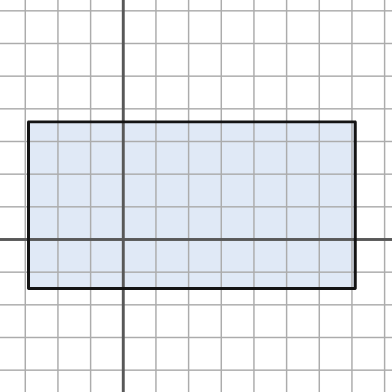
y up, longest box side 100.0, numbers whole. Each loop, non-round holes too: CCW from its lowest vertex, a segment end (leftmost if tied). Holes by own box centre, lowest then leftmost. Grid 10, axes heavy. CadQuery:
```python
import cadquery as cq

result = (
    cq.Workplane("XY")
    .moveTo(-29.0, -15.0)
    .lineTo(71.0, -15.0)
    .lineTo(71.0, 36.0)
    .lineTo(-29.0, 36.0)
    .close()
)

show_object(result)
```